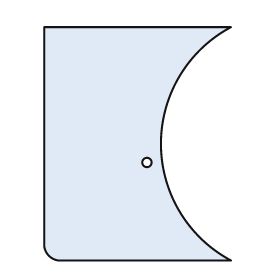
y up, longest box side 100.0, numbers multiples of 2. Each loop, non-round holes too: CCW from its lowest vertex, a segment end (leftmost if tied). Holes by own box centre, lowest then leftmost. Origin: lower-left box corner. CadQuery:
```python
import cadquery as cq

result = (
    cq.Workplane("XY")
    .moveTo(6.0, 0.0)
    .lineTo(80.0, 0.0)
    .threePointArc((50.0, 50.0), (80.0, 100.0))
    .lineTo(0.0, 100.0)
    .lineTo(0.0, 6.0)
    .threePointArc((2.0, 2.0), (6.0, 0.0))
    .close()
    .moveTo(44.0, 42.0)
    .circle(2.0)
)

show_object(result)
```